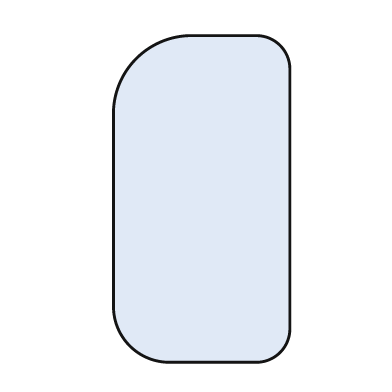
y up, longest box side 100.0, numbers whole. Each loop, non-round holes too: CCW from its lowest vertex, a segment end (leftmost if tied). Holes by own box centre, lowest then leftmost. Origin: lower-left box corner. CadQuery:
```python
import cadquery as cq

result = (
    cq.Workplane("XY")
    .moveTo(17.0, 0.0)
    .lineTo(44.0, 0.0)
    .threePointArc((51.0, 3.0), (54.0, 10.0))
    .lineTo(54.0, 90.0)
    .threePointArc((51.0, 97.0), (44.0, 100.0))
    .lineTo(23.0, 100.0)
    .threePointArc((7.0, 93.0), (0.0, 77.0))
    .lineTo(0.0, 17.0)
    .threePointArc((5.0, 5.0), (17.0, 0.0))
    .close()
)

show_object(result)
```